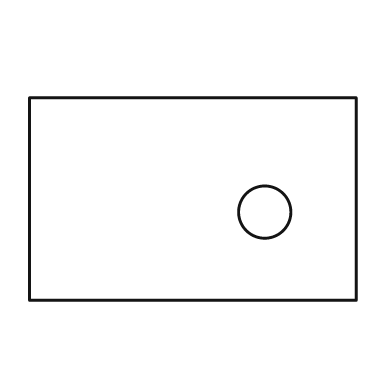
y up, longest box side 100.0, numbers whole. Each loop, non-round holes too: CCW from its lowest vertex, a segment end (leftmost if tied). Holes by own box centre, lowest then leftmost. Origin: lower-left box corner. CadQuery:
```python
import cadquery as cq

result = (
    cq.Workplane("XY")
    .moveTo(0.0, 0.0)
    .lineTo(100.0, 0.0)
    .lineTo(100.0, 62.0)
    .lineTo(0.0, 62.0)
    .close()
    .moveTo(72.0, 27.0)
    .circle(8.0)
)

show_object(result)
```